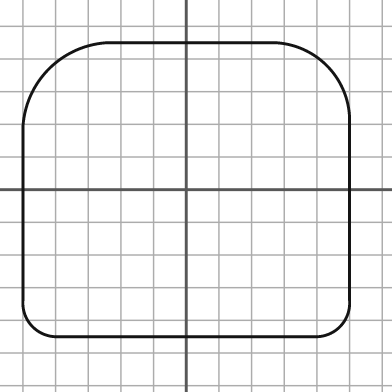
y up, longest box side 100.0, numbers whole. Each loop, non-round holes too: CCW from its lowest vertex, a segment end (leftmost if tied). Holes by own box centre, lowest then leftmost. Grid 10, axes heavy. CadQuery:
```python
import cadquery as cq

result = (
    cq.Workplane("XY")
    .moveTo(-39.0, -45.0)
    .lineTo(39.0, -45.0)
    .threePointArc((47.0, -42.0), (50.0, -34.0))
    .lineTo(50.0, 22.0)
    .threePointArc((43.0, 38.0), (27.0, 45.0))
    .lineTo(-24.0, 45.0)
    .threePointArc((-42.0, 37.0), (-50.0, 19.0))
    .lineTo(-50.0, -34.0)
    .threePointArc((-47.0, -42.0), (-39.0, -45.0))
    .close()
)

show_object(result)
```